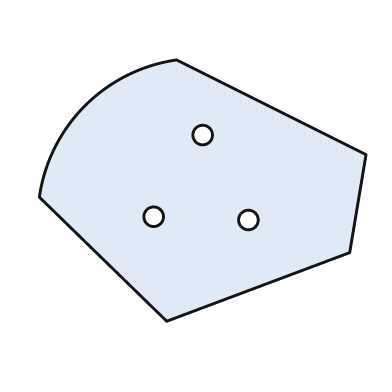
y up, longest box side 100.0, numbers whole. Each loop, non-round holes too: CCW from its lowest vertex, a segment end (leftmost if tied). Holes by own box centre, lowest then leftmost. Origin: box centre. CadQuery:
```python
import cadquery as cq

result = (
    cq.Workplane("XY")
    .moveTo(-11.0, -40.0)
    .lineTo(45.0, -19.0)
    .lineTo(50.0, 11.0)
    .lineTo(-8.0, 40.0)
    .threePointArc((-36.0, 26.0), (-50.0, -2.0))
    .close()
    .moveTo(14.0, -9.0)
    .circle(3.0)
    .moveTo(-15.0, -8.0)
    .circle(3.0)
    .moveTo(0.0, 17.0)
    .circle(3.0)
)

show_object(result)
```